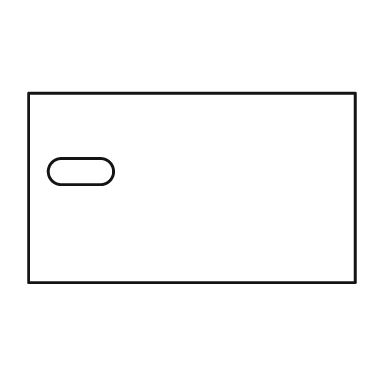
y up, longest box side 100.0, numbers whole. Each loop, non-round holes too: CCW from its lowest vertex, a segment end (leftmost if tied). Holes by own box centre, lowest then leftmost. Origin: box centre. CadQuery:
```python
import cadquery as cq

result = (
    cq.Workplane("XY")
    .moveTo(-50.0, -29.0)
    .lineTo(50.0, -29.0)
    .lineTo(50.0, 29.0)
    .lineTo(-50.0, 29.0)
    .close()
    .moveTo(-40.0, 1.0)
    .lineTo(-28.0, 1.0)
    .threePointArc((-24.0, 5.0), (-28.0, 9.0))
    .lineTo(-40.0, 9.0)
    .threePointArc((-44.0, 5.0), (-40.0, 1.0))
    .close()
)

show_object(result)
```